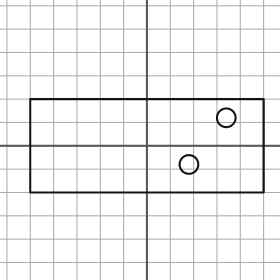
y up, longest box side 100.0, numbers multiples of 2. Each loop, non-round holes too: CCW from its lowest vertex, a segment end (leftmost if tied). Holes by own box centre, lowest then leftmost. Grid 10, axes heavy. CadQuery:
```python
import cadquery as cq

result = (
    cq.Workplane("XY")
    .moveTo(-50.0, -20.0)
    .lineTo(50.0, -20.0)
    .lineTo(50.0, 20.0)
    .lineTo(-50.0, 20.0)
    .close()
    .moveTo(18.0, -8.0)
    .circle(4.0)
    .moveTo(34.0, 12.0)
    .circle(4.0)
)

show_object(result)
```